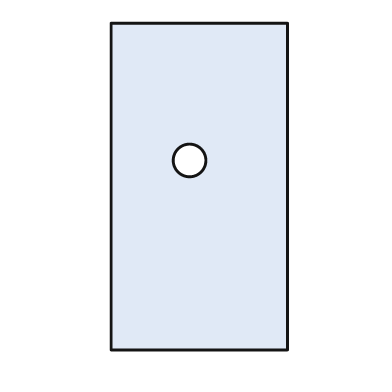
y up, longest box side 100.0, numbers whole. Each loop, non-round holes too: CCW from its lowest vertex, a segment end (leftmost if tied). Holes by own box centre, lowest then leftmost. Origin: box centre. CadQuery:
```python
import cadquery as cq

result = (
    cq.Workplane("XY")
    .moveTo(-27.0, -50.0)
    .lineTo(27.0, -50.0)
    .lineTo(27.0, 50.0)
    .lineTo(-27.0, 50.0)
    .close()
    .moveTo(-3.0, 8.0)
    .circle(5.0)
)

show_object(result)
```